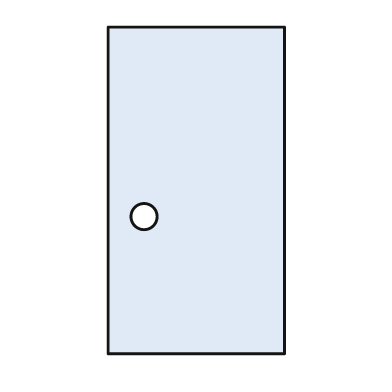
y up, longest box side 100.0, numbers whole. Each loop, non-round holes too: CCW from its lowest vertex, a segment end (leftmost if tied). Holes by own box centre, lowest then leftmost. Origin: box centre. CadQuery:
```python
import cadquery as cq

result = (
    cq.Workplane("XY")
    .moveTo(-27.0, -50.0)
    .lineTo(27.0, -50.0)
    .lineTo(27.0, 50.0)
    .lineTo(-27.0, 50.0)
    .close()
    .moveTo(-16.0, -8.0)
    .circle(4.0)
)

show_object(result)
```